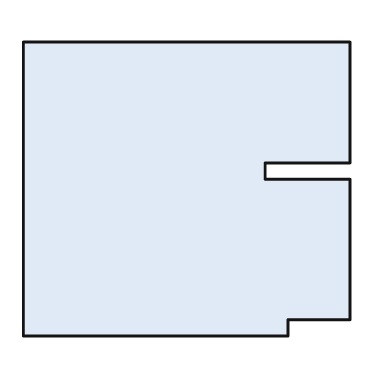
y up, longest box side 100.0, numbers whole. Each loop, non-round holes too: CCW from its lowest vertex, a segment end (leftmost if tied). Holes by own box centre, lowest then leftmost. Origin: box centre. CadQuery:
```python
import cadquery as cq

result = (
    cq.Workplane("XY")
    .moveTo(-50.0, -45.0)
    .lineTo(31.0, -45.0)
    .lineTo(31.0, -40.0)
    .lineTo(50.0, -40.0)
    .lineTo(50.0, 3.0)
    .lineTo(24.0, 3.0)
    .lineTo(24.0, 8.0)
    .lineTo(50.0, 8.0)
    .lineTo(50.0, 45.0)
    .lineTo(-50.0, 45.0)
    .close()
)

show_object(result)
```